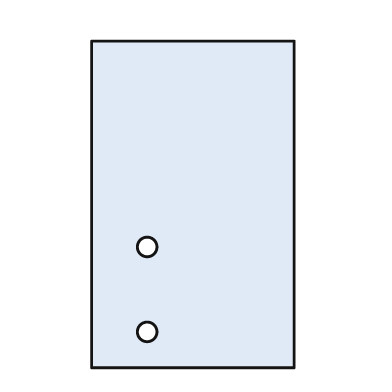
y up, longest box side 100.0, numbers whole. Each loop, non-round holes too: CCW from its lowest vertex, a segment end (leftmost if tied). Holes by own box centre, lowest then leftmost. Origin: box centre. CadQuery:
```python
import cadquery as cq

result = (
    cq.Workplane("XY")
    .moveTo(-31.0, -50.0)
    .lineTo(31.0, -50.0)
    .lineTo(31.0, 50.0)
    .lineTo(-31.0, 50.0)
    .close()
    .moveTo(-14.0, -39.0)
    .circle(3.0)
    .moveTo(-14.0, -13.0)
    .circle(3.0)
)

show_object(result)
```